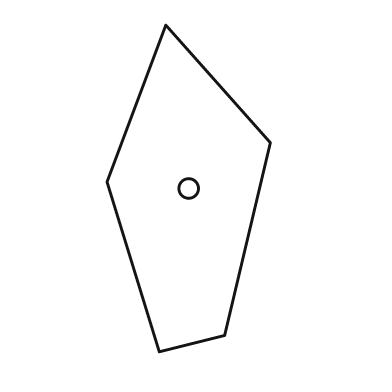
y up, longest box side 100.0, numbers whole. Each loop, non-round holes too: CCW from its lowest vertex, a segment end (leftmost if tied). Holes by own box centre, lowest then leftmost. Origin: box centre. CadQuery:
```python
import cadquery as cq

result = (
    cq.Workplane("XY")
    .moveTo(-9.0, -50.0)
    .lineTo(11.0, -45.0)
    .lineTo(25.0, 14.0)
    .lineTo(-7.0, 50.0)
    .lineTo(-25.0, 2.0)
    .close()
    .moveTo(0.0, 0.0)
    .circle(3.0)
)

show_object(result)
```